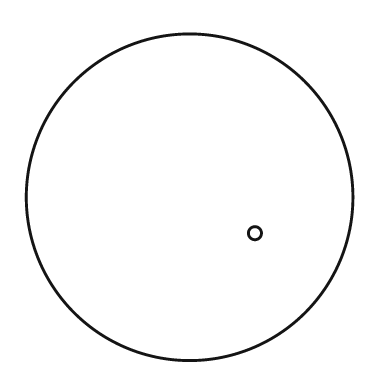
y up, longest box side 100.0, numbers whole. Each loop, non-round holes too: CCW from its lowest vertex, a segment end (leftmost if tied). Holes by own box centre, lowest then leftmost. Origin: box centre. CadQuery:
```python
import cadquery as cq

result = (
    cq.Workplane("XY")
    .moveTo(0.0, 0.0)
    .circle(50.0)
    .moveTo(20.0, -11.0)
    .circle(2.0)
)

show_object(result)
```